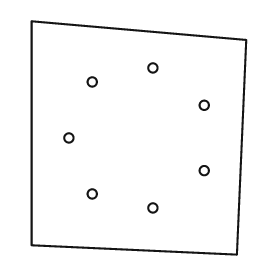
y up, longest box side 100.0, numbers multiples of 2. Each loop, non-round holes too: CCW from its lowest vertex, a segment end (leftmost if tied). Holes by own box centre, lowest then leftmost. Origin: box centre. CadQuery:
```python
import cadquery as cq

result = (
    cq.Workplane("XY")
    .moveTo(42.0, -50.0)
    .lineTo(46.0, 42.0)
    .lineTo(-46.0, 50.0)
    .lineTo(-46.0, -46.0)
    .close()
    .moveTo(6.0, -30.0)
    .circle(2.0)
    .moveTo(-20.0, -24.0)
    .circle(2.0)
    .moveTo(28.0, -14.0)
    .circle(2.0)
    .moveTo(-30.0, 0.0)
    .circle(2.0)
    .moveTo(28.0, 14.0)
    .circle(2.0)
    .moveTo(-20.0, 24.0)
    .circle(2.0)
    .moveTo(6.0, 30.0)
    .circle(2.0)
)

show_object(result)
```